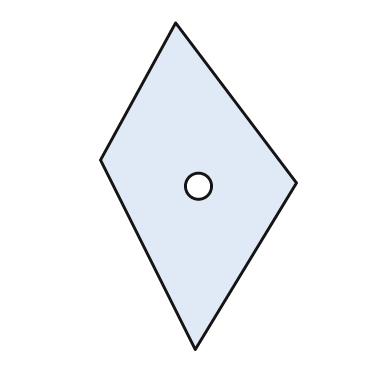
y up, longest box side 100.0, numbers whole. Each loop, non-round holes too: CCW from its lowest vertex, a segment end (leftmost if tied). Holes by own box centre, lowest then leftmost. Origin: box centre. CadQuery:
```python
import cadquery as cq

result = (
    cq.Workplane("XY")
    .moveTo(-1.0, -50.0)
    .lineTo(30.0, 1.0)
    .lineTo(-7.0, 50.0)
    .lineTo(-30.0, 8.0)
    .close()
    .moveTo(0.0, 0.0)
    .circle(4.0)
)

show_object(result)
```